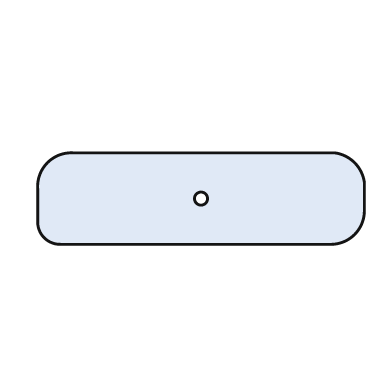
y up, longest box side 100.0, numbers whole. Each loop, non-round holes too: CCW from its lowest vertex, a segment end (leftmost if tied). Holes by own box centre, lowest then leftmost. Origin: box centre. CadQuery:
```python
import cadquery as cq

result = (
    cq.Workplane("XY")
    .moveTo(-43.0, -14.0)
    .lineTo(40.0, -14.0)
    .threePointArc((47.0, -11.0), (50.0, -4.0))
    .lineTo(50.0, 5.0)
    .threePointArc((47.0, 11.0), (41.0, 14.0))
    .lineTo(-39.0, 14.0)
    .threePointArc((-47.0, 11.0), (-50.0, 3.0))
    .lineTo(-50.0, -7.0)
    .threePointArc((-48.0, -12.0), (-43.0, -14.0))
    .close()
    .moveTo(0.0, 0.0)
    .circle(2.0)
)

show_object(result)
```